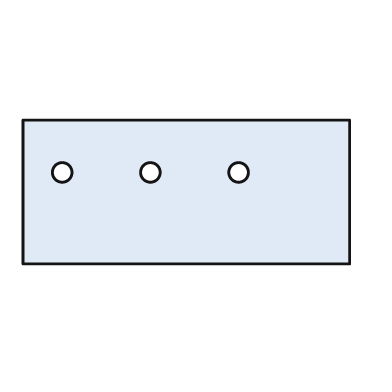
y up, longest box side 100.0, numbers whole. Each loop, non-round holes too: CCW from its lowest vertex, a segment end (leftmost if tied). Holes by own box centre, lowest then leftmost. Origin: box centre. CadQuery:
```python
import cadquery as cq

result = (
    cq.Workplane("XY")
    .moveTo(-50.0, -22.0)
    .lineTo(50.0, -22.0)
    .lineTo(50.0, 22.0)
    .lineTo(-50.0, 22.0)
    .close()
    .moveTo(-38.0, 6.0)
    .circle(3.0)
    .moveTo(-11.0, 6.0)
    .circle(3.0)
    .moveTo(16.0, 6.0)
    .circle(3.0)
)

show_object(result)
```